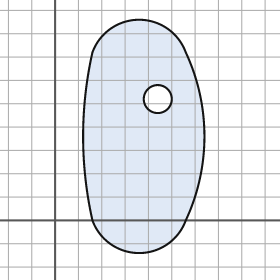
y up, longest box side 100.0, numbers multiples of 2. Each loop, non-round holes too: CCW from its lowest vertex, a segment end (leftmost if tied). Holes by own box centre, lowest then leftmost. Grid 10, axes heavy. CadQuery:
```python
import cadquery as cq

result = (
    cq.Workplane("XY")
    .moveTo(16.0, 0.0)
    .threePointArc((36.0, -14.0), (56.0, 0.0))
    .threePointArc((64.0, 36.0), (56.0, 72.0))
    .threePointArc((36.0, 86.0), (16.0, 72.0))
    .threePointArc((12.0, 36.0), (16.0, 0.0))
    .close()
    .moveTo(44.0, 52.0)
    .circle(6.0)
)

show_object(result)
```